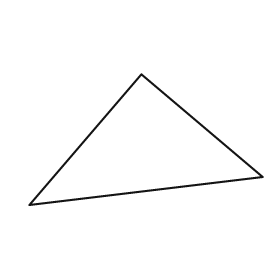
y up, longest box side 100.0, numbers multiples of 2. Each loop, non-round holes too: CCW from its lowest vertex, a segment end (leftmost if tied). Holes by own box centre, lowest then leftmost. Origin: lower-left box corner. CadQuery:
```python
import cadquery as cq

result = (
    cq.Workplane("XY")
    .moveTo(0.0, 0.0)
    .lineTo(100.0, 12.0)
    .lineTo(48.0, 56.0)
    .close()
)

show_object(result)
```